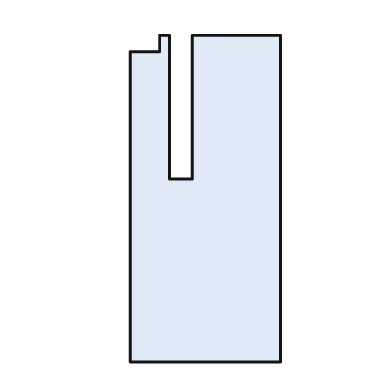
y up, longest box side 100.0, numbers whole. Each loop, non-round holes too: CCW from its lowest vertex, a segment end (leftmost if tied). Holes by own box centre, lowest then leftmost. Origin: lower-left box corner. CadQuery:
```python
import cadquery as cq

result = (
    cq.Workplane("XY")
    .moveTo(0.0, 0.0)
    .lineTo(46.0, 0.0)
    .lineTo(46.0, 100.0)
    .lineTo(19.0, 100.0)
    .lineTo(19.0, 56.0)
    .lineTo(12.0, 56.0)
    .lineTo(12.0, 100.0)
    .lineTo(9.0, 100.0)
    .lineTo(9.0, 95.0)
    .lineTo(0.0, 95.0)
    .close()
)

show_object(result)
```